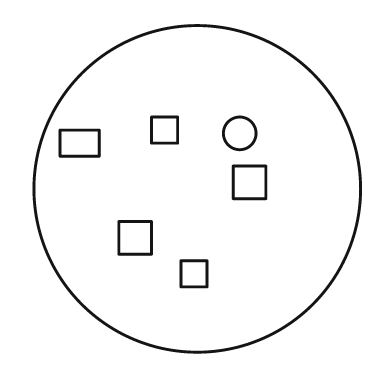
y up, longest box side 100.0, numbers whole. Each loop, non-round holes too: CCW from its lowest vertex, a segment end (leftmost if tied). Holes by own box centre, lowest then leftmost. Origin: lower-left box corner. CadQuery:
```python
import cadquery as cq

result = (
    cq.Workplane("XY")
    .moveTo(50.0, 50.0)
    .circle(50.0)
    .moveTo(45.0, 20.0)
    .lineTo(53.0, 20.0)
    .lineTo(53.0, 28.0)
    .lineTo(45.0, 28.0)
    .close()
    .moveTo(26.0, 30.0)
    .lineTo(36.0, 30.0)
    .lineTo(36.0, 40.0)
    .lineTo(26.0, 40.0)
    .close()
    .moveTo(61.0, 47.0)
    .lineTo(71.0, 47.0)
    .lineTo(71.0, 57.0)
    .lineTo(61.0, 57.0)
    .close()
    .moveTo(8.0, 60.0)
    .lineTo(20.0, 60.0)
    .lineTo(20.0, 68.0)
    .lineTo(8.0, 68.0)
    .close()
    .moveTo(63.0, 67.0)
    .circle(5.0)
    .moveTo(36.0, 64.0)
    .lineTo(44.0, 64.0)
    .lineTo(44.0, 72.0)
    .lineTo(36.0, 72.0)
    .close()
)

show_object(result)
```